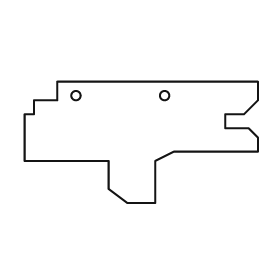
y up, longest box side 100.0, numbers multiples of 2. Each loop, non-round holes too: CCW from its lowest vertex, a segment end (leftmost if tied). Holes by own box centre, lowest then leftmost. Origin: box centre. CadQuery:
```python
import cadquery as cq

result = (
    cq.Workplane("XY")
    .moveTo(-6.0, -26.0)
    .lineTo(6.0, -26.0)
    .lineTo(6.0, -8.0)
    .lineTo(14.0, -4.0)
    .lineTo(50.0, -4.0)
    .lineTo(50.0, 2.0)
    .lineTo(46.0, 6.0)
    .lineTo(36.0, 6.0)
    .lineTo(36.0, 12.0)
    .lineTo(44.0, 12.0)
    .lineTo(50.0, 18.0)
    .lineTo(50.0, 26.0)
    .lineTo(-36.0, 26.0)
    .lineTo(-36.0, 18.0)
    .lineTo(-46.0, 18.0)
    .lineTo(-46.0, 12.0)
    .lineTo(-50.0, 12.0)
    .lineTo(-50.0, -8.0)
    .lineTo(-14.0, -8.0)
    .lineTo(-14.0, -20.0)
    .close()
    .moveTo(-28.0, 20.0)
    .circle(2.0)
    .moveTo(10.0, 20.0)
    .circle(2.0)
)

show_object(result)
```